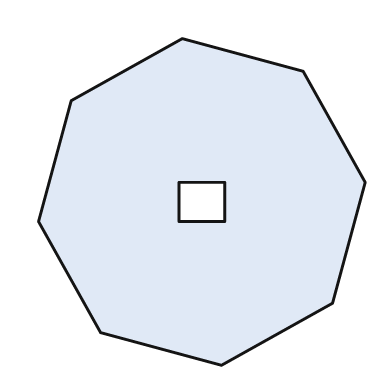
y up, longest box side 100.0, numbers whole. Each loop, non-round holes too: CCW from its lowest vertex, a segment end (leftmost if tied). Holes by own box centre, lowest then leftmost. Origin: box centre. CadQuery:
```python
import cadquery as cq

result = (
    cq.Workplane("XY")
    .moveTo(6.0, -50.0)
    .lineTo(40.0, -31.0)
    .lineTo(50.0, 6.0)
    .lineTo(31.0, 40.0)
    .lineTo(-6.0, 50.0)
    .lineTo(-40.0, 31.0)
    .lineTo(-50.0, -6.0)
    .lineTo(-31.0, -40.0)
    .close()
    .moveTo(-7.0, -6.0)
    .lineTo(7.0, -6.0)
    .lineTo(7.0, 6.0)
    .lineTo(-7.0, 6.0)
    .close()
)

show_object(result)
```